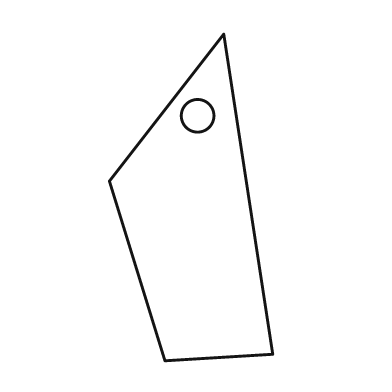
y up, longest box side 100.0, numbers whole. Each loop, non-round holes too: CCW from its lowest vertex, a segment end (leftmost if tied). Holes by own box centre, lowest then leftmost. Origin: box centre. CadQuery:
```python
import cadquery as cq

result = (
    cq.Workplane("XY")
    .moveTo(-8.0, -50.0)
    .lineTo(25.0, -48.0)
    .lineTo(10.0, 50.0)
    .lineTo(-25.0, 5.0)
    .close()
    .moveTo(2.0, 25.0)
    .circle(5.0)
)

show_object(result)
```